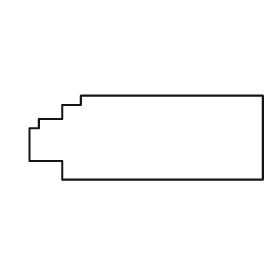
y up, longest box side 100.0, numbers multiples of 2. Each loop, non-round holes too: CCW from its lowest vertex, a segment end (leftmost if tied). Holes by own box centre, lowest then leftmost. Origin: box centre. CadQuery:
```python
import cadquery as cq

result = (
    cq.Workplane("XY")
    .moveTo(-36.0, -18.0)
    .lineTo(50.0, -18.0)
    .lineTo(50.0, 18.0)
    .lineTo(-28.0, 18.0)
    .lineTo(-28.0, 14.0)
    .lineTo(-36.0, 14.0)
    .lineTo(-36.0, 8.0)
    .lineTo(-46.0, 8.0)
    .lineTo(-46.0, 4.0)
    .lineTo(-50.0, 4.0)
    .lineTo(-50.0, -10.0)
    .lineTo(-36.0, -10.0)
    .close()
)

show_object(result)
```